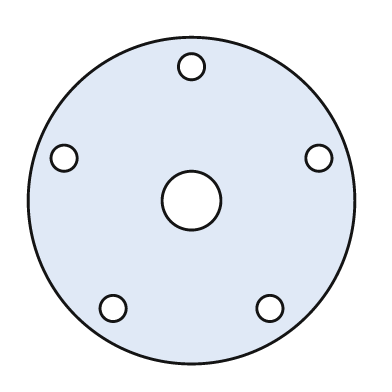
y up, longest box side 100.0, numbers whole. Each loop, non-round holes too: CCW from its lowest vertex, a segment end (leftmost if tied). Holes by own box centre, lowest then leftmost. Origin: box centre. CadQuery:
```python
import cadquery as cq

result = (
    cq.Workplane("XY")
    .moveTo(0.0, 0.0)
    .circle(50.0)
    .moveTo(-24.0, -33.0)
    .circle(4.0)
    .moveTo(24.0, -33.0)
    .circle(4.0)
    .moveTo(0.0, 0.0)
    .circle(9.0)
    .moveTo(-39.0, 13.0)
    .circle(4.0)
    .moveTo(39.0, 13.0)
    .circle(4.0)
    .moveTo(0.0, 41.0)
    .circle(4.0)
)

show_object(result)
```